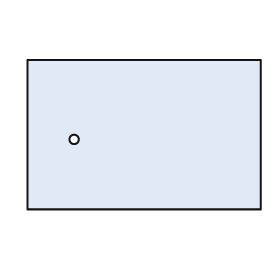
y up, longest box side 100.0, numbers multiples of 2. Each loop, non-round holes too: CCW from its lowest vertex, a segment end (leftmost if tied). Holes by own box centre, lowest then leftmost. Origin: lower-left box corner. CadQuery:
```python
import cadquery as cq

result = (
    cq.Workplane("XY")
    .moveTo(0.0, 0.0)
    .lineTo(100.0, 0.0)
    .lineTo(100.0, 64.0)
    .lineTo(0.0, 64.0)
    .close()
    .moveTo(20.0, 30.0)
    .circle(2.0)
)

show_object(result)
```